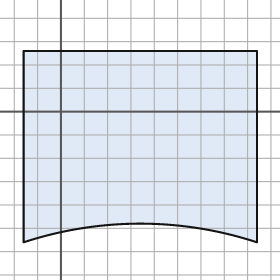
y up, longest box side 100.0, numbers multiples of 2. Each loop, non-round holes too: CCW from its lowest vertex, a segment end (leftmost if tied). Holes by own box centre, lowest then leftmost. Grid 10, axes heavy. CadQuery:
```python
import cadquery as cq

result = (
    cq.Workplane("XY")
    .moveTo(-16.0, -56.0)
    .threePointArc((34.0, -48.0), (84.0, -56.0))
    .lineTo(84.0, 26.0)
    .lineTo(-16.0, 26.0)
    .close()
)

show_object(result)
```